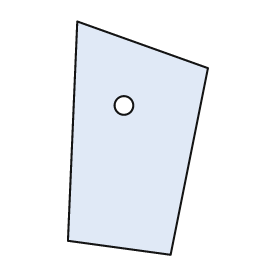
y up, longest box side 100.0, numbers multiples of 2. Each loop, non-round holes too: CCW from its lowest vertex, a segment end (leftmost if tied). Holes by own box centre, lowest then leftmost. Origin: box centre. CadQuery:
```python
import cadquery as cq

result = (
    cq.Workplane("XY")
    .moveTo(14.0, -50.0)
    .lineTo(30.0, 30.0)
    .lineTo(-26.0, 50.0)
    .lineTo(-30.0, -44.0)
    .close()
    .moveTo(-6.0, 14.0)
    .circle(4.0)
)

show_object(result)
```